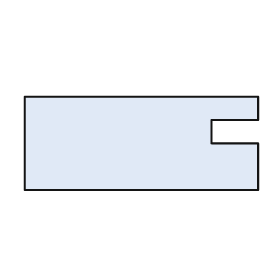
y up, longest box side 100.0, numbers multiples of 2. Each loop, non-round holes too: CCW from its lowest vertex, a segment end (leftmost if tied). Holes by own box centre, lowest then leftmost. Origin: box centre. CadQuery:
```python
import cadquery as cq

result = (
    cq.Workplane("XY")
    .moveTo(-50.0, -20.0)
    .lineTo(50.0, -20.0)
    .lineTo(50.0, 0.0)
    .lineTo(30.0, 0.0)
    .lineTo(30.0, 10.0)
    .lineTo(50.0, 10.0)
    .lineTo(50.0, 20.0)
    .lineTo(-50.0, 20.0)
    .close()
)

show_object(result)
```